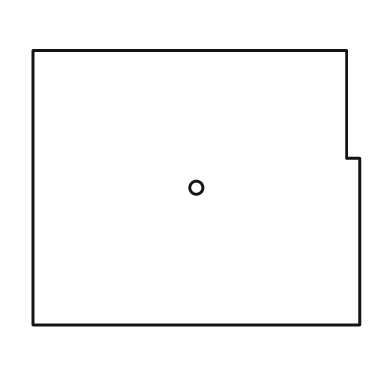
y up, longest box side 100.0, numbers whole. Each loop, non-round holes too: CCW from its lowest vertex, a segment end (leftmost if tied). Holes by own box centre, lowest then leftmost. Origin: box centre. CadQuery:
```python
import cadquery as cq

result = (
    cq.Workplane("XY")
    .moveTo(-50.0, -42.0)
    .lineTo(50.0, -42.0)
    .lineTo(50.0, 9.0)
    .lineTo(46.0, 9.0)
    .lineTo(46.0, 42.0)
    .lineTo(-50.0, 42.0)
    .close()
    .moveTo(0.0, 0.0)
    .circle(2.0)
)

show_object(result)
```